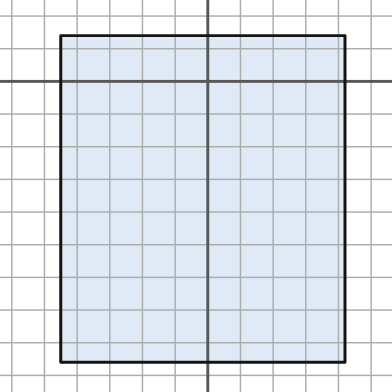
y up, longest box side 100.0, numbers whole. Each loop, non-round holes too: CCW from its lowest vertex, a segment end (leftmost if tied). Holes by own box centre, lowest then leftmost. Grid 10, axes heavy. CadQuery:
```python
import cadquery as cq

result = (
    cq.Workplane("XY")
    .moveTo(-45.0, -86.0)
    .lineTo(42.0, -86.0)
    .lineTo(42.0, 14.0)
    .lineTo(-45.0, 14.0)
    .close()
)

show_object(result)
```